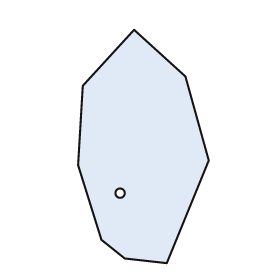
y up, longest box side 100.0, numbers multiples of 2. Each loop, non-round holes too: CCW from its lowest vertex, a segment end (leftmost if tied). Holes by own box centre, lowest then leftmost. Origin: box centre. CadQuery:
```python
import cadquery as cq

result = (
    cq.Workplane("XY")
    .moveTo(10.0, -50.0)
    .lineTo(28.0, -6.0)
    .lineTo(18.0, 30.0)
    .lineTo(-4.0, 50.0)
    .lineTo(-26.0, 26.0)
    .lineTo(-28.0, -8.0)
    .lineTo(-18.0, -40.0)
    .lineTo(-8.0, -48.0)
    .close()
    .moveTo(-10.0, -20.0)
    .circle(2.0)
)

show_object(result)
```